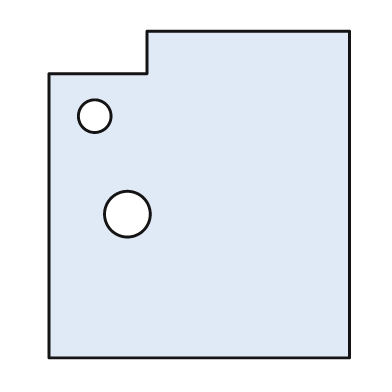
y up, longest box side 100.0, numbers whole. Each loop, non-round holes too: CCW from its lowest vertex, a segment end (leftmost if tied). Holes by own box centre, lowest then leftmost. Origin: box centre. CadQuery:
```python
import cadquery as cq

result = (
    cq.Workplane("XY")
    .moveTo(-46.0, -50.0)
    .lineTo(46.0, -50.0)
    .lineTo(46.0, 50.0)
    .lineTo(-16.0, 50.0)
    .lineTo(-16.0, 37.0)
    .lineTo(-46.0, 37.0)
    .close()
    .moveTo(-22.0, -6.0)
    .circle(7.0)
    .moveTo(-32.0, 24.0)
    .circle(5.0)
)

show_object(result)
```